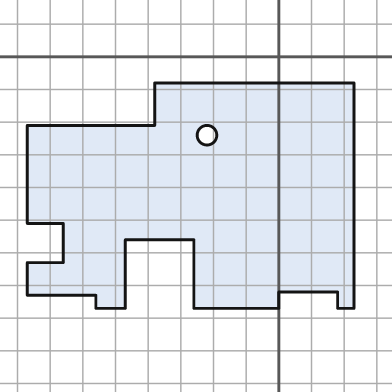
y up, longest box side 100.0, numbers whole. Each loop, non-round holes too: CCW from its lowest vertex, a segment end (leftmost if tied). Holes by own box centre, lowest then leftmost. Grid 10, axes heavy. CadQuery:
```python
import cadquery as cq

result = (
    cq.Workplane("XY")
    .moveTo(-56.0, -77.0)
    .lineTo(-47.0, -77.0)
    .lineTo(-47.0, -56.0)
    .lineTo(-26.0, -56.0)
    .lineTo(-26.0, -77.0)
    .lineTo(0.0, -77.0)
    .lineTo(0.0, -72.0)
    .lineTo(18.0, -72.0)
    .lineTo(18.0, -77.0)
    .lineTo(23.0, -77.0)
    .lineTo(23.0, -8.0)
    .lineTo(-38.0, -8.0)
    .lineTo(-38.0, -21.0)
    .lineTo(-77.0, -21.0)
    .lineTo(-77.0, -51.0)
    .lineTo(-66.0, -51.0)
    .lineTo(-66.0, -63.0)
    .lineTo(-77.0, -63.0)
    .lineTo(-77.0, -73.0)
    .lineTo(-56.0, -73.0)
    .close()
    .moveTo(-22.0, -24.0)
    .circle(3.0)
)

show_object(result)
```